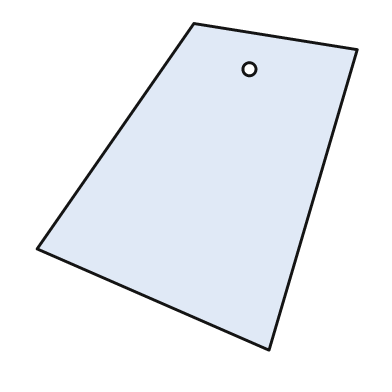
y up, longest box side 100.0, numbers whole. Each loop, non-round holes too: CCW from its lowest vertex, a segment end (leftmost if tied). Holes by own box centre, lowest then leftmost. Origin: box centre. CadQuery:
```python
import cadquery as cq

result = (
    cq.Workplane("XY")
    .moveTo(22.0, -50.0)
    .lineTo(49.0, 42.0)
    .lineTo(-1.0, 50.0)
    .lineTo(-49.0, -19.0)
    .close()
    .moveTo(16.0, 36.0)
    .circle(2.0)
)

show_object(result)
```